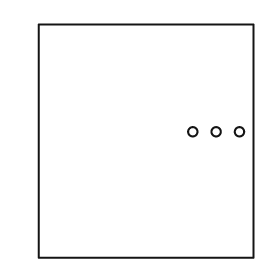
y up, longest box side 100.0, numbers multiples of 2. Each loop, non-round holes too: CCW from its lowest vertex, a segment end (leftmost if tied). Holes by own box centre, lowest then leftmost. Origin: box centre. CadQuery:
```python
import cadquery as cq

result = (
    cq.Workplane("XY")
    .moveTo(-46.0, -50.0)
    .lineTo(46.0, -50.0)
    .lineTo(46.0, 50.0)
    .lineTo(-46.0, 50.0)
    .close()
    .moveTo(20.0, 4.0)
    .circle(2.0)
    .moveTo(30.0, 4.0)
    .circle(2.0)
    .moveTo(40.0, 4.0)
    .circle(2.0)
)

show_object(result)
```